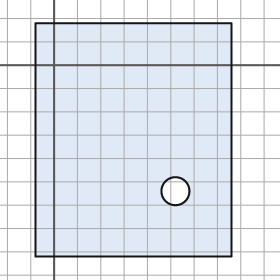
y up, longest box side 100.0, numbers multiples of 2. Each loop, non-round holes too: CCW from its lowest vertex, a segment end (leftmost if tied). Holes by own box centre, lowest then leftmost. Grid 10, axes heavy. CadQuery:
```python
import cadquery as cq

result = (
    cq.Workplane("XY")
    .moveTo(-8.0, -82.0)
    .lineTo(76.0, -82.0)
    .lineTo(76.0, 18.0)
    .lineTo(-8.0, 18.0)
    .close()
    .moveTo(52.0, -54.0)
    .circle(6.0)
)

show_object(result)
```